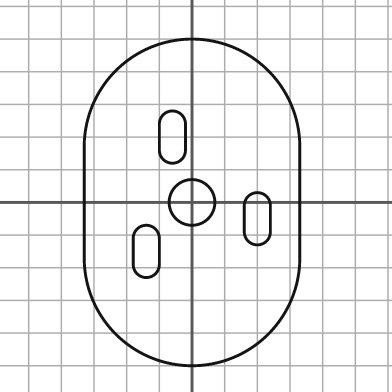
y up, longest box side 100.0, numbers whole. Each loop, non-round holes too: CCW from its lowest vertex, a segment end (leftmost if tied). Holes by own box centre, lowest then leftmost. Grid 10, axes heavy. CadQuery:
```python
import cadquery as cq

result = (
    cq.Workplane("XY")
    .moveTo(-33.0, -17.0)
    .threePointArc((0.0, -50.0), (33.0, -17.0))
    .lineTo(33.0, 17.0)
    .threePointArc((0.0, 50.0), (-33.0, 17.0))
    .close()
    .moveTo(-18.0, -19.0)
    .threePointArc((-14.0, -23.0), (-10.0, -19.0))
    .lineTo(-10.0, -11.0)
    .threePointArc((-14.0, -7.0), (-18.0, -11.0))
    .close()
    .moveTo(16.0, -9.0)
    .threePointArc((20.0, -13.0), (24.0, -9.0))
    .lineTo(24.0, -1.0)
    .threePointArc((20.0, 3.0), (16.0, -1.0))
    .close()
    .moveTo(0.0, 0.0)
    .circle(7.0)
    .moveTo(-10.0, 16.0)
    .threePointArc((-6.0, 12.0), (-2.0, 16.0))
    .lineTo(-2.0, 24.0)
    .threePointArc((-6.0, 28.0), (-10.0, 24.0))
    .close()
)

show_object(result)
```